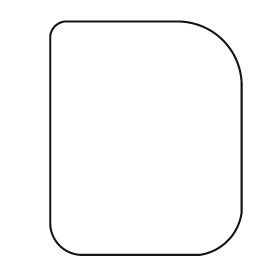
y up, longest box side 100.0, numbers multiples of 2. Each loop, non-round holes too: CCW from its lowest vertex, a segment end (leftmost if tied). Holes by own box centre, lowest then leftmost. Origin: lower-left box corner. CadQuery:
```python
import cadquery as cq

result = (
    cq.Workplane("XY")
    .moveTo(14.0, 0.0)
    .lineTo(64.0, 0.0)
    .threePointArc((76.0, 6.0), (82.0, 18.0))
    .lineTo(82.0, 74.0)
    .threePointArc((74.0, 92.0), (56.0, 100.0))
    .lineTo(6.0, 100.0)
    .threePointArc((2.0, 98.0), (0.0, 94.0))
    .lineTo(0.0, 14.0)
    .threePointArc((4.0, 4.0), (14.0, 0.0))
    .close()
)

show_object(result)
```